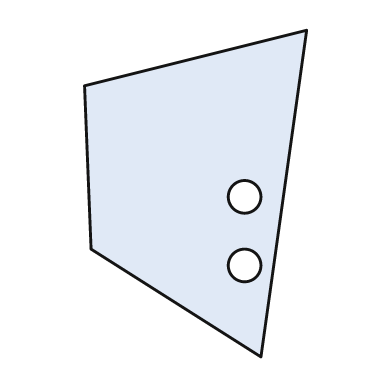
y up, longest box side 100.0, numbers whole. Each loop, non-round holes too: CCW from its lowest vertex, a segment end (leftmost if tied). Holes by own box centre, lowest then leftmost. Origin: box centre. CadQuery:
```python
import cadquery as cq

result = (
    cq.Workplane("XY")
    .moveTo(20.0, -50.0)
    .lineTo(34.0, 50.0)
    .lineTo(-34.0, 33.0)
    .lineTo(-32.0, -17.0)
    .close()
    .moveTo(15.0, -22.0)
    .circle(5.0)
    .moveTo(15.0, -1.0)
    .circle(5.0)
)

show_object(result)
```